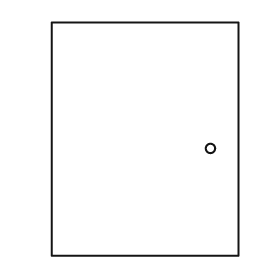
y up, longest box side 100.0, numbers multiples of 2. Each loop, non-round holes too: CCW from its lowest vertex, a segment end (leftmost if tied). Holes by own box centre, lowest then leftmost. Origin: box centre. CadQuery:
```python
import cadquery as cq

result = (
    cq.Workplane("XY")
    .moveTo(-40.0, -50.0)
    .lineTo(40.0, -50.0)
    .lineTo(40.0, 50.0)
    .lineTo(-40.0, 50.0)
    .close()
    .moveTo(28.0, -4.0)
    .circle(2.0)
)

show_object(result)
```